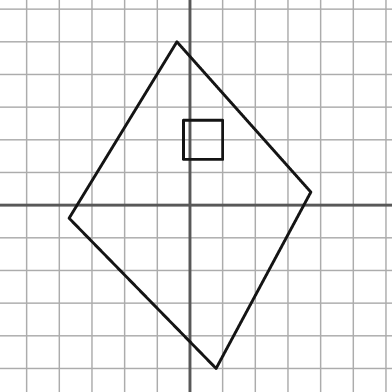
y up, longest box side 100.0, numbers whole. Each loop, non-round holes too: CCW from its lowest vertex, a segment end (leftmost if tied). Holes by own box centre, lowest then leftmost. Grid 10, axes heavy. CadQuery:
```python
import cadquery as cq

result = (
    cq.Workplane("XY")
    .moveTo(8.0, -50.0)
    .lineTo(37.0, 4.0)
    .lineTo(-4.0, 50.0)
    .lineTo(-37.0, -4.0)
    .close()
    .moveTo(-2.0, 14.0)
    .lineTo(10.0, 14.0)
    .lineTo(10.0, 26.0)
    .lineTo(-2.0, 26.0)
    .close()
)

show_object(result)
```